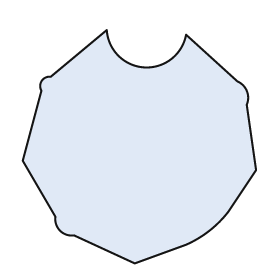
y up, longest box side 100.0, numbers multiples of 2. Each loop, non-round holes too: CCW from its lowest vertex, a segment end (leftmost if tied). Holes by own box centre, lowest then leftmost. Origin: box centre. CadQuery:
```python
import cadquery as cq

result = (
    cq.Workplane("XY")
    .moveTo(-2.0, -50.0)
    .lineTo(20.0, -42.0)
    .threePointArc((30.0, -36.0), (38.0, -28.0))
    .lineTo(50.0, -10.0)
    .lineTo(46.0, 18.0)
    .threePointArc((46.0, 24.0), (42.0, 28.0))
    .lineTo(20.0, 48.0)
    .threePointArc((2.0, 34.0), (-14.0, 50.0))
    .lineTo(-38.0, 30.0)
    .threePointArc((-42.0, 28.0), (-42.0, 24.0))
    .lineTo(-50.0, -6.0)
    .lineTo(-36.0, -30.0)
    .threePointArc((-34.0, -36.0), (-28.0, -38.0))
    .close()
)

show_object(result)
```